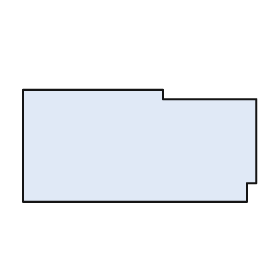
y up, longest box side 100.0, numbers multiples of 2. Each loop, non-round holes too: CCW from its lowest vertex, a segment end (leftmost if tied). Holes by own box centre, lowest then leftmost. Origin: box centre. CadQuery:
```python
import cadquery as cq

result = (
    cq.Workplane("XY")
    .moveTo(-50.0, -24.0)
    .lineTo(46.0, -24.0)
    .lineTo(46.0, -16.0)
    .lineTo(50.0, -16.0)
    .lineTo(50.0, 20.0)
    .lineTo(10.0, 20.0)
    .lineTo(10.0, 24.0)
    .lineTo(-50.0, 24.0)
    .close()
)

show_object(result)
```